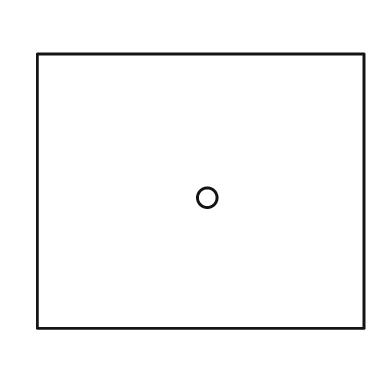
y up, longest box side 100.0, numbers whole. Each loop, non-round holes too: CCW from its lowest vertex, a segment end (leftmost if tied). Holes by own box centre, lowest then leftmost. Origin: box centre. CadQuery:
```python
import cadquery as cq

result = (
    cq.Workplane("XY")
    .moveTo(-50.0, -42.0)
    .lineTo(50.0, -42.0)
    .lineTo(50.0, 42.0)
    .lineTo(-50.0, 42.0)
    .close()
    .moveTo(2.0, -2.0)
    .circle(3.0)
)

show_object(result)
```